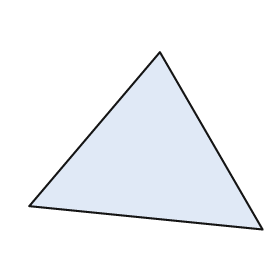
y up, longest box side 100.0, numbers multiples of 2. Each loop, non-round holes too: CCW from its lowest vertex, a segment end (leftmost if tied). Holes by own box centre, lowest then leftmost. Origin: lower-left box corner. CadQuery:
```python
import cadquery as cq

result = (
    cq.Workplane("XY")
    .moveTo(100.0, 0.0)
    .lineTo(56.0, 76.0)
    .lineTo(0.0, 10.0)
    .close()
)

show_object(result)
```